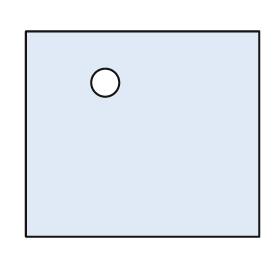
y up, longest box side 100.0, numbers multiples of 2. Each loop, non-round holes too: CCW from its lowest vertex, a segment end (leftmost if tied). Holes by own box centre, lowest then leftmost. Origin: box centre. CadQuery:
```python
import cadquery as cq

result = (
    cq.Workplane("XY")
    .moveTo(-50.0, -44.0)
    .lineTo(50.0, -44.0)
    .lineTo(50.0, 44.0)
    .lineTo(-50.0, 44.0)
    .close()
    .moveTo(-16.0, 22.0)
    .circle(6.0)
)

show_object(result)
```